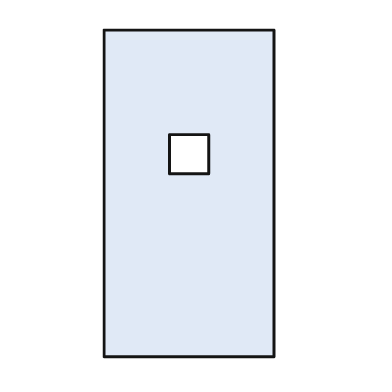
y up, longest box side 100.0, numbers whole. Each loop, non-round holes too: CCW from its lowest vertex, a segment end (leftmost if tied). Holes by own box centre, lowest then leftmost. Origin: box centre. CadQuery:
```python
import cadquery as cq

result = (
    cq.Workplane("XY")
    .moveTo(-26.0, -50.0)
    .lineTo(26.0, -50.0)
    .lineTo(26.0, 50.0)
    .lineTo(-26.0, 50.0)
    .close()
    .moveTo(-6.0, 6.0)
    .lineTo(6.0, 6.0)
    .lineTo(6.0, 18.0)
    .lineTo(-6.0, 18.0)
    .close()
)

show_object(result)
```